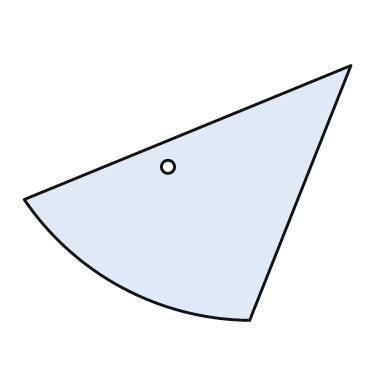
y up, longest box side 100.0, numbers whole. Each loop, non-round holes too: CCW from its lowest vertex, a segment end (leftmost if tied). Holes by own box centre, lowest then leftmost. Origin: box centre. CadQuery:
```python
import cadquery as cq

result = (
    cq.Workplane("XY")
    .moveTo(19.0, -39.0)
    .lineTo(50.0, 39.0)
    .lineTo(-50.0, -2.0)
    .threePointArc((-20.0, -29.0), (19.0, -39.0))
    .close()
    .moveTo(-6.0, 8.0)
    .circle(2.0)
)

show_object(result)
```